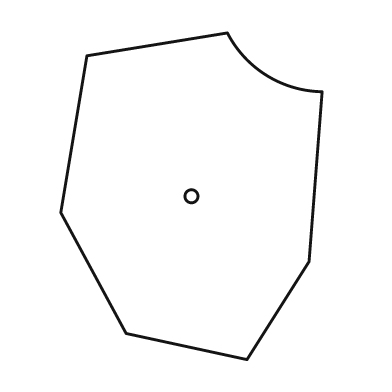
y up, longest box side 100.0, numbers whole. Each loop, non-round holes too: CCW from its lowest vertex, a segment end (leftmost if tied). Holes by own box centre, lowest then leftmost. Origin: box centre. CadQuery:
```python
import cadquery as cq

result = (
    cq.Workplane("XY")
    .moveTo(17.0, -50.0)
    .lineTo(36.0, -20.0)
    .lineTo(40.0, 32.0)
    .threePointArc((23.0, 37.0), (11.0, 50.0))
    .lineTo(-32.0, 43.0)
    .lineTo(-40.0, -5.0)
    .lineTo(-20.0, -42.0)
    .close()
    .moveTo(0.0, 0.0)
    .circle(2.0)
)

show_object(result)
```